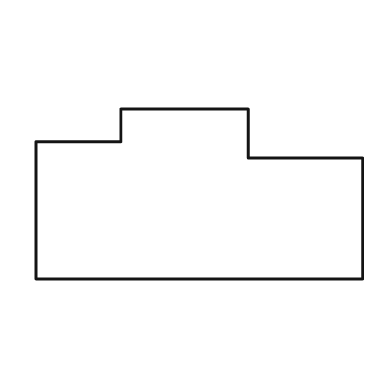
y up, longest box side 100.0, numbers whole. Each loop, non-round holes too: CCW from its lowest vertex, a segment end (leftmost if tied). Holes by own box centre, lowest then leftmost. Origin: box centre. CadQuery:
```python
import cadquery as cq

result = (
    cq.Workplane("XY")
    .moveTo(-50.0, -26.0)
    .lineTo(50.0, -26.0)
    .lineTo(50.0, 11.0)
    .lineTo(15.0, 11.0)
    .lineTo(15.0, 26.0)
    .lineTo(-24.0, 26.0)
    .lineTo(-24.0, 16.0)
    .lineTo(-50.0, 16.0)
    .close()
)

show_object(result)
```